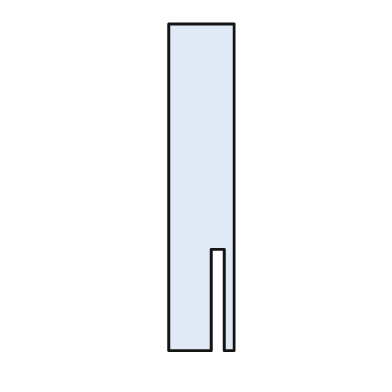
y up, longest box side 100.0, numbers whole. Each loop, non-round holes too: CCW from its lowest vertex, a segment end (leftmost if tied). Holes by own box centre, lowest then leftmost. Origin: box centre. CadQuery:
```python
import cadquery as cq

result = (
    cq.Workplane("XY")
    .moveTo(-10.0, -50.0)
    .lineTo(3.0, -50.0)
    .lineTo(3.0, -19.0)
    .lineTo(7.0, -19.0)
    .lineTo(7.0, -50.0)
    .lineTo(10.0, -50.0)
    .lineTo(10.0, 50.0)
    .lineTo(-10.0, 50.0)
    .close()
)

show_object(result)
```